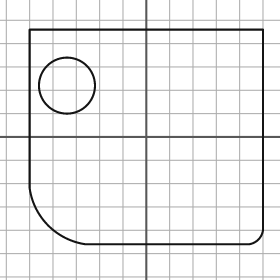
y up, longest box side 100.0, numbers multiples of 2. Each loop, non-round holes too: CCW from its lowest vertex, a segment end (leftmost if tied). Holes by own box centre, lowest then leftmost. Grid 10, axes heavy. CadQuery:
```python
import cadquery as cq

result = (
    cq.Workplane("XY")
    .moveTo(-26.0, -46.0)
    .lineTo(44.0, -46.0)
    .threePointArc((48.0, -44.0), (50.0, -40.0))
    .lineTo(50.0, 46.0)
    .lineTo(-50.0, 46.0)
    .lineTo(-50.0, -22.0)
    .threePointArc((-42.0, -38.0), (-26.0, -46.0))
    .close()
    .moveTo(-34.0, 22.0)
    .circle(12.0)
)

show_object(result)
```